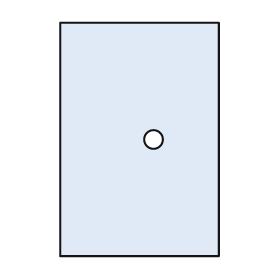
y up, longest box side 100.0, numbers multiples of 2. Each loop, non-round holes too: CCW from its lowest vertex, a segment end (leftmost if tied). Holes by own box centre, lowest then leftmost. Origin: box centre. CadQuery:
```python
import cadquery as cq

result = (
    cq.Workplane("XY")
    .moveTo(-34.0, -50.0)
    .lineTo(34.0, -50.0)
    .lineTo(34.0, 50.0)
    .lineTo(-34.0, 50.0)
    .close()
    .moveTo(6.0, 0.0)
    .circle(4.0)
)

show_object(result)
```